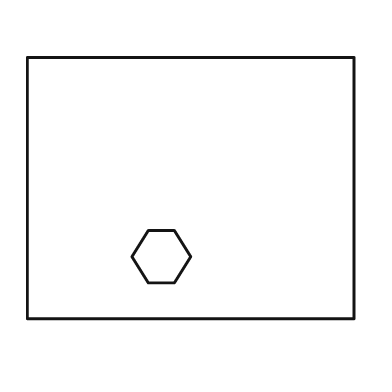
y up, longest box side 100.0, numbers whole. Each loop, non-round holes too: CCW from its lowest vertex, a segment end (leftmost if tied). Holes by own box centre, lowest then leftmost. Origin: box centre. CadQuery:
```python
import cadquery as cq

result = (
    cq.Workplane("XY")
    .moveTo(-50.0, -40.0)
    .lineTo(50.0, -40.0)
    .lineTo(50.0, 40.0)
    .lineTo(-50.0, 40.0)
    .close()
    .moveTo(-13.0, -29.0)
    .lineTo(-5.0, -29.0)
    .lineTo(0.0, -21.0)
    .lineTo(-5.0, -13.0)
    .lineTo(-13.0, -13.0)
    .lineTo(-18.0, -21.0)
    .close()
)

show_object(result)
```